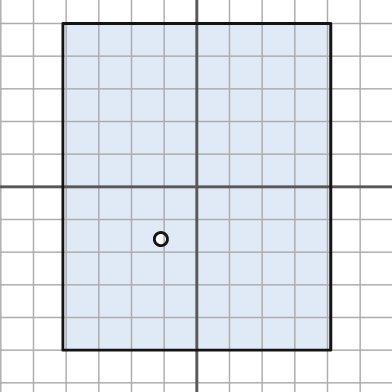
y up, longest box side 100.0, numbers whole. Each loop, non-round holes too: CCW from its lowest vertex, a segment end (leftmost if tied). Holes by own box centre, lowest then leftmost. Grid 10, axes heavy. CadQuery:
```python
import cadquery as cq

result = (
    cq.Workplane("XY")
    .moveTo(-41.0, -50.0)
    .lineTo(41.0, -50.0)
    .lineTo(41.0, 50.0)
    .lineTo(-41.0, 50.0)
    .close()
    .moveTo(-11.0, -16.0)
    .circle(2.0)
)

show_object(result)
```